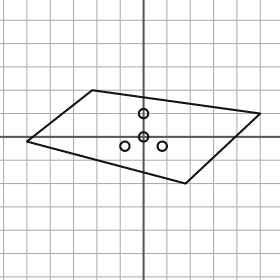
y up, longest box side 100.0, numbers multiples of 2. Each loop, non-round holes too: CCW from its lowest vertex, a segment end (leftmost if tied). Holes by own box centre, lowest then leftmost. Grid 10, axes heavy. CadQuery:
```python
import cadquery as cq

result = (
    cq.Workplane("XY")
    .moveTo(18.0, -20.0)
    .lineTo(50.0, 10.0)
    .lineTo(-22.0, 20.0)
    .lineTo(-50.0, -2.0)
    .close()
    .moveTo(-8.0, -4.0)
    .circle(2.0)
    .moveTo(8.0, -4.0)
    .circle(2.0)
    .moveTo(0.0, 0.0)
    .circle(2.0)
    .moveTo(0.0, 10.0)
    .circle(2.0)
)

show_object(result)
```